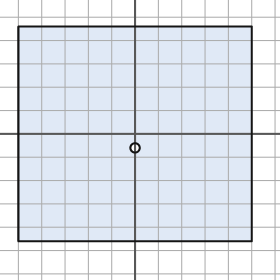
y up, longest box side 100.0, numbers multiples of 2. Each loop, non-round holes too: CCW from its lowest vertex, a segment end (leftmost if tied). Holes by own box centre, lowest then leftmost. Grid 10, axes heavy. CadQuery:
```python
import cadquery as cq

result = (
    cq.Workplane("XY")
    .moveTo(-50.0, -46.0)
    .lineTo(50.0, -46.0)
    .lineTo(50.0, 46.0)
    .lineTo(-50.0, 46.0)
    .close()
    .moveTo(0.0, -6.0)
    .circle(2.0)
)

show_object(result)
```